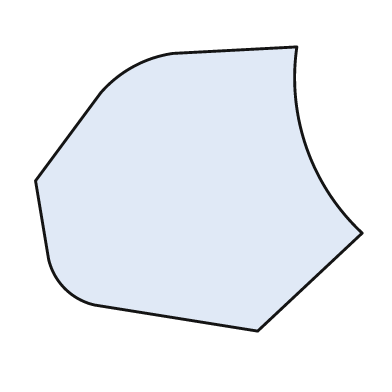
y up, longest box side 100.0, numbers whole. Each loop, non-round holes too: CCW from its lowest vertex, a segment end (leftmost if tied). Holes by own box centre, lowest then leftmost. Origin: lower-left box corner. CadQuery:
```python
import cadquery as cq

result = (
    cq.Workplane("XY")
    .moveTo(68.0, 0.0)
    .lineTo(100.0, 30.0)
    .threePointArc((83.0, 56.0), (80.0, 87.0))
    .lineTo(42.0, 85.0)
    .threePointArc((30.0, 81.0), (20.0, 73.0))
    .lineTo(0.0, 46.0)
    .lineTo(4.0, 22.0)
    .threePointArc((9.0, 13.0), (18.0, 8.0))
    .close()
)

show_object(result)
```